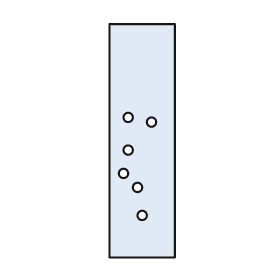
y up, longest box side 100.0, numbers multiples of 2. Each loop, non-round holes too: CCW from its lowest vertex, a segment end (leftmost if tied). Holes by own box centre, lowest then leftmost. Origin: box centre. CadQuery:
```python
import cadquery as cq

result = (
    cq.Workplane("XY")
    .moveTo(-14.0, -50.0)
    .lineTo(14.0, -50.0)
    .lineTo(14.0, 50.0)
    .lineTo(-14.0, 50.0)
    .close()
    .moveTo(0.0, -32.0)
    .circle(2.0)
    .moveTo(-2.0, -20.0)
    .circle(2.0)
    .moveTo(-8.0, -14.0)
    .circle(2.0)
    .moveTo(-6.0, -4.0)
    .circle(2.0)
    .moveTo(4.0, 8.0)
    .circle(2.0)
    .moveTo(-6.0, 10.0)
    .circle(2.0)
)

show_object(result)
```